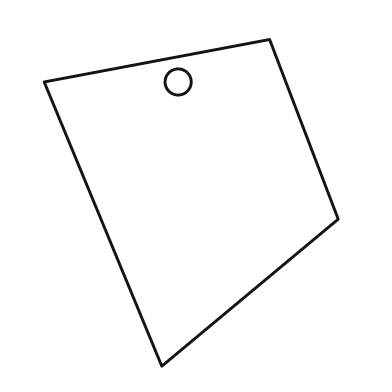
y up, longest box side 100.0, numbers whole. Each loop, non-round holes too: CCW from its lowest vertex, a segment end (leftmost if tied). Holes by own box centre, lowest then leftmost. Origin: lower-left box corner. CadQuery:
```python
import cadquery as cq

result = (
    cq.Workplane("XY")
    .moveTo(36.0, 0.0)
    .lineTo(90.0, 45.0)
    .lineTo(69.0, 100.0)
    .lineTo(0.0, 87.0)
    .close()
    .moveTo(41.0, 87.0)
    .circle(4.0)
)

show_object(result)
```